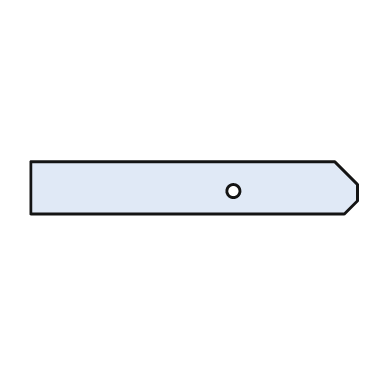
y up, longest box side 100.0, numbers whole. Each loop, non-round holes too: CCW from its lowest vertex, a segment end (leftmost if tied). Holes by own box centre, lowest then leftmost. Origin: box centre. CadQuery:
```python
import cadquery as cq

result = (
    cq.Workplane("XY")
    .moveTo(-50.0, -8.0)
    .lineTo(46.0, -8.0)
    .lineTo(50.0, -4.0)
    .lineTo(50.0, 1.0)
    .lineTo(43.0, 8.0)
    .lineTo(-50.0, 8.0)
    .close()
    .moveTo(12.0, -1.0)
    .circle(2.0)
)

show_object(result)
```